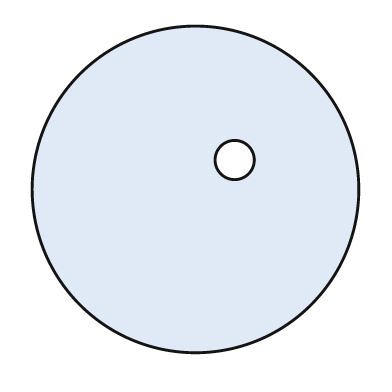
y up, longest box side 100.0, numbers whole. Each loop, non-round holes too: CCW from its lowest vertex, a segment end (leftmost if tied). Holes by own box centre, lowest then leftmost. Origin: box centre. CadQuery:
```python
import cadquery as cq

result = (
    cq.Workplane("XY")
    .moveTo(0.0, 0.0)
    .circle(50.0)
    .moveTo(12.0, 9.0)
    .circle(6.0)
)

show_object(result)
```